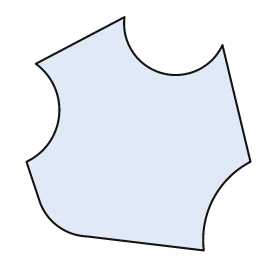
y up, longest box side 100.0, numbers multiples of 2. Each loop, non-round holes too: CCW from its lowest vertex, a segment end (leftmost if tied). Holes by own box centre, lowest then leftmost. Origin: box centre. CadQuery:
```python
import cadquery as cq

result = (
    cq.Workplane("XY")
    .moveTo(28.0, -50.0)
    .threePointArc((32.0, -28.0), (48.0, -12.0))
    .lineTo(36.0, 38.0)
    .threePointArc((10.0, 26.0), (-6.0, 50.0))
    .lineTo(-44.0, 30.0)
    .threePointArc((-34.0, 8.0), (-48.0, -12.0))
    .lineTo(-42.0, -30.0)
    .threePointArc((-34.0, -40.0), (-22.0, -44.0))
    .close()
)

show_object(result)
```